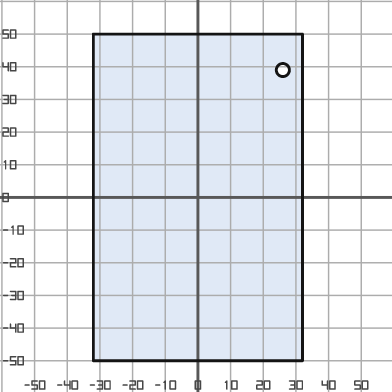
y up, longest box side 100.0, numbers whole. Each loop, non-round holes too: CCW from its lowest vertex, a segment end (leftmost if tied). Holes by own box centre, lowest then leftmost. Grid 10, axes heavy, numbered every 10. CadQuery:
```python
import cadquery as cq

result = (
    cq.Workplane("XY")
    .moveTo(-32.0, -50.0)
    .lineTo(32.0, -50.0)
    .lineTo(32.0, 50.0)
    .lineTo(-32.0, 50.0)
    .close()
    .moveTo(26.0, 39.0)
    .circle(2.0)
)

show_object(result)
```